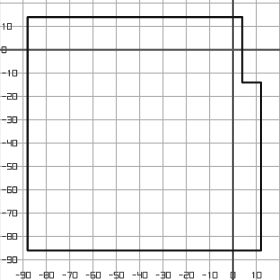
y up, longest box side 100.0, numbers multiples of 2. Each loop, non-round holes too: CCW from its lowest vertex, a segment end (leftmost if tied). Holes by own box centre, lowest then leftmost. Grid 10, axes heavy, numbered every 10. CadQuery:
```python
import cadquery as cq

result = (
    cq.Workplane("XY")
    .moveTo(-88.0, -86.0)
    .lineTo(12.0, -86.0)
    .lineTo(12.0, -14.0)
    .lineTo(4.0, -14.0)
    .lineTo(4.0, 14.0)
    .lineTo(-88.0, 14.0)
    .close()
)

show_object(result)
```